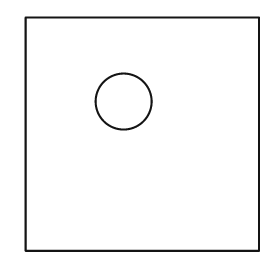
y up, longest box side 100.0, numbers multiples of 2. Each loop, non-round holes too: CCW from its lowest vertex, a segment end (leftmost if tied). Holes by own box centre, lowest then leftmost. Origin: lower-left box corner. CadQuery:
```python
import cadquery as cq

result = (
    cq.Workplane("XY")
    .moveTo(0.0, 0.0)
    .lineTo(100.0, 0.0)
    .lineTo(100.0, 100.0)
    .lineTo(0.0, 100.0)
    .close()
    .moveTo(42.0, 64.0)
    .circle(12.0)
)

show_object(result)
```